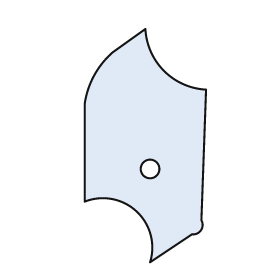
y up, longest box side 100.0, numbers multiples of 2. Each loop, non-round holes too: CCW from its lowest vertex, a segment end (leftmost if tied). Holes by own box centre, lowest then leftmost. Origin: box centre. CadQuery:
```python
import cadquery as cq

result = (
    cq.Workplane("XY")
    .moveTo(2.0, -50.0)
    .lineTo(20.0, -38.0)
    .threePointArc((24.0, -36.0), (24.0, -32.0))
    .lineTo(26.0, 24.0)
    .threePointArc((8.0, 32.0), (0.0, 50.0))
    .lineTo(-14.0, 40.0)
    .threePointArc((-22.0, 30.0), (-26.0, 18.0))
    .lineTo(-26.0, -24.0)
    .threePointArc((-4.0, -28.0), (2.0, -50.0))
    .close()
    .moveTo(2.0, -10.0)
    .circle(4.0)
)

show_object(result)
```